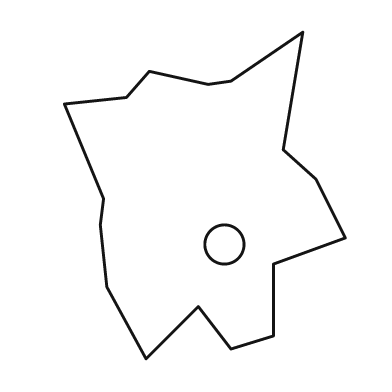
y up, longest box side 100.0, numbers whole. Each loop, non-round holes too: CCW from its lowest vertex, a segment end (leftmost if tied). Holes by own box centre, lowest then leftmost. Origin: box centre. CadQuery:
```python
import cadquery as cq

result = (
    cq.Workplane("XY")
    .moveTo(-18.0, -50.0)
    .lineTo(-2.0, -34.0)
    .lineTo(8.0, -47.0)
    .lineTo(21.0, -43.0)
    .lineTo(21.0, -21.0)
    .lineTo(43.0, -13.0)
    .lineTo(34.0, 5.0)
    .lineTo(24.0, 14.0)
    .lineTo(30.0, 50.0)
    .lineTo(8.0, 35.0)
    .lineTo(1.0, 34.0)
    .lineTo(-17.0, 38.0)
    .lineTo(-24.0, 30.0)
    .lineTo(-43.0, 28.0)
    .lineTo(-31.0, -1.0)
    .lineTo(-32.0, -9.0)
    .lineTo(-30.0, -28.0)
    .close()
    .moveTo(6.0, -15.0)
    .circle(6.0)
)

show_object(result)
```